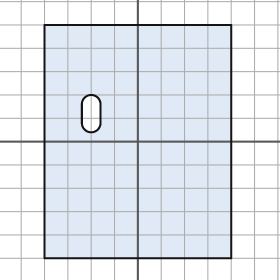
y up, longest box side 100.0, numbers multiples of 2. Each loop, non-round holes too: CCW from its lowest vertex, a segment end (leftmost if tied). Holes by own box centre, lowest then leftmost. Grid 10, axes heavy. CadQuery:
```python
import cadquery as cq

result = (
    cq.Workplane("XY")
    .moveTo(-40.0, -50.0)
    .lineTo(40.0, -50.0)
    .lineTo(40.0, 50.0)
    .lineTo(-40.0, 50.0)
    .close()
    .moveTo(-24.0, 8.0)
    .threePointArc((-20.0, 4.0), (-16.0, 8.0))
    .lineTo(-16.0, 16.0)
    .threePointArc((-20.0, 20.0), (-24.0, 16.0))
    .close()
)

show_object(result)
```